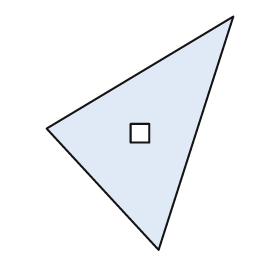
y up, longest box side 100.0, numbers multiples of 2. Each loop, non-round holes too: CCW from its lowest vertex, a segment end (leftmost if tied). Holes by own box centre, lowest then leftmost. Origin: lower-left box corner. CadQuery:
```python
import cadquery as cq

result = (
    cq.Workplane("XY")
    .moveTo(48.0, 0.0)
    .lineTo(80.0, 100.0)
    .lineTo(0.0, 52.0)
    .close()
    .moveTo(36.0, 46.0)
    .lineTo(44.0, 46.0)
    .lineTo(44.0, 54.0)
    .lineTo(36.0, 54.0)
    .close()
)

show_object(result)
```